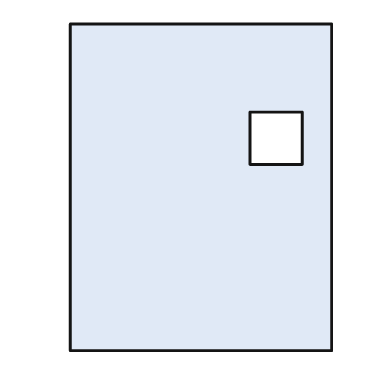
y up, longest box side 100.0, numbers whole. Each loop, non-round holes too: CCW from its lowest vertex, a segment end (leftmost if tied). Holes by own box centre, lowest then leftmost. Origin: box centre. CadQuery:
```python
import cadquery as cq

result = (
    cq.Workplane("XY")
    .moveTo(-40.0, -50.0)
    .lineTo(40.0, -50.0)
    .lineTo(40.0, 50.0)
    .lineTo(-40.0, 50.0)
    .close()
    .moveTo(15.0, 7.0)
    .lineTo(31.0, 7.0)
    .lineTo(31.0, 23.0)
    .lineTo(15.0, 23.0)
    .close()
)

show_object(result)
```